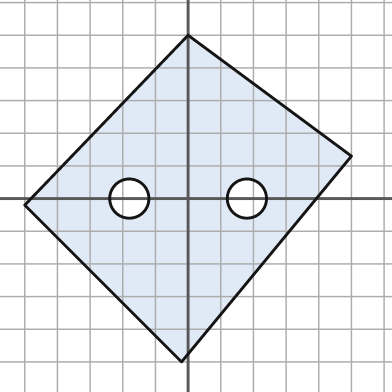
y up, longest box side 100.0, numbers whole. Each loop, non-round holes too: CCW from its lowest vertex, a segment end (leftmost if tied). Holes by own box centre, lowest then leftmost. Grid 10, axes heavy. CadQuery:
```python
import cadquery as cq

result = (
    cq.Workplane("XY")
    .moveTo(-2.0, -50.0)
    .lineTo(50.0, 13.0)
    .lineTo(0.0, 50.0)
    .lineTo(-50.0, -2.0)
    .close()
    .moveTo(-18.0, 0.0)
    .circle(6.0)
    .moveTo(18.0, 0.0)
    .circle(6.0)
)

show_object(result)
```